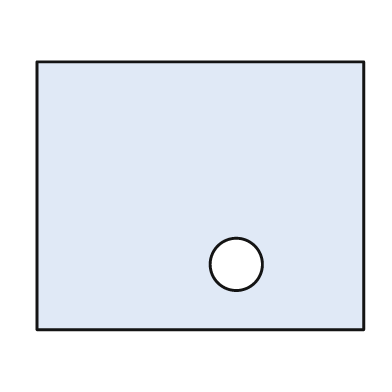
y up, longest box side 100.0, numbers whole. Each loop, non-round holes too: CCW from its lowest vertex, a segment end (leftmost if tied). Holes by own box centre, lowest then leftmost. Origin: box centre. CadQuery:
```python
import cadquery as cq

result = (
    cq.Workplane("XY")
    .moveTo(-50.0, -41.0)
    .lineTo(50.0, -41.0)
    .lineTo(50.0, 41.0)
    .lineTo(-50.0, 41.0)
    .close()
    .moveTo(11.0, -21.0)
    .circle(8.0)
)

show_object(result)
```